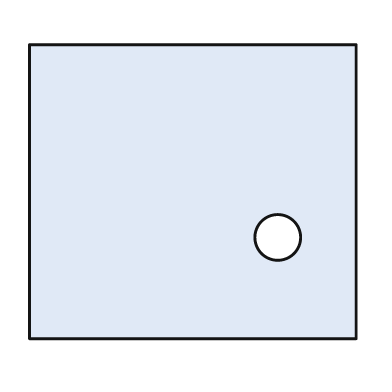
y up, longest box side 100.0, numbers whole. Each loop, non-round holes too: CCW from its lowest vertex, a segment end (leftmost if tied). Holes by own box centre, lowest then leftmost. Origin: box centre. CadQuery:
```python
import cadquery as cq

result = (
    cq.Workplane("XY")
    .moveTo(-50.0, -45.0)
    .lineTo(50.0, -45.0)
    .lineTo(50.0, 45.0)
    .lineTo(-50.0, 45.0)
    .close()
    .moveTo(26.0, -14.0)
    .circle(7.0)
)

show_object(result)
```